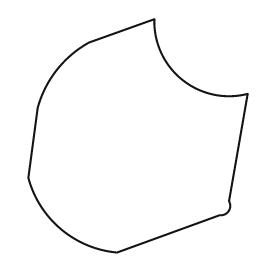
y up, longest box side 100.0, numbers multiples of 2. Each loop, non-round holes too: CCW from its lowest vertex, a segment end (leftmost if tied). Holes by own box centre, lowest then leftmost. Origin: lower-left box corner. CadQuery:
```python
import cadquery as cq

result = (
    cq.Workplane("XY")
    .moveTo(38.0, 0.0)
    .lineTo(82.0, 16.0)
    .threePointArc((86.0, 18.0), (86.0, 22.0))
    .lineTo(94.0, 68.0)
    .threePointArc((66.0, 74.0), (54.0, 100.0))
    .lineTo(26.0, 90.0)
    .threePointArc((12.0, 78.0), (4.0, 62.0))
    .lineTo(0.0, 32.0)
    .threePointArc((14.0, 10.0), (38.0, 0.0))
    .close()
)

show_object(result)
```